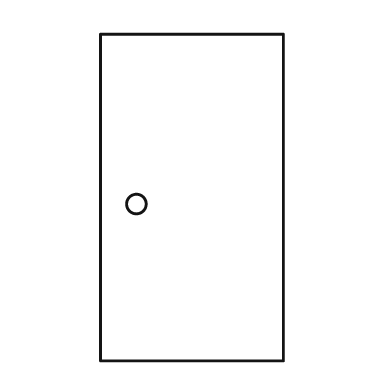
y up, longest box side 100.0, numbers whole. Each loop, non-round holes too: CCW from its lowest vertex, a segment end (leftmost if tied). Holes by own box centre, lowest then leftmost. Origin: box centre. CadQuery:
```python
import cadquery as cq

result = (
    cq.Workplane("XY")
    .moveTo(-28.0, -50.0)
    .lineTo(28.0, -50.0)
    .lineTo(28.0, 50.0)
    .lineTo(-28.0, 50.0)
    .close()
    .moveTo(-17.0, -2.0)
    .circle(3.0)
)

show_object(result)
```